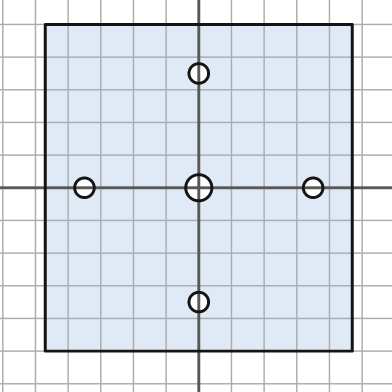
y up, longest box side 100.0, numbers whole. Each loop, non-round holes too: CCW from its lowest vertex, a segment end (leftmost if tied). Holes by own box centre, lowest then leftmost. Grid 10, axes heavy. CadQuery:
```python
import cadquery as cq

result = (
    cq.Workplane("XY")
    .moveTo(-47.0, -50.0)
    .lineTo(47.0, -50.0)
    .lineTo(47.0, 50.0)
    .lineTo(-47.0, 50.0)
    .close()
    .moveTo(0.0, -35.0)
    .circle(3.0)
    .moveTo(-35.0, 0.0)
    .circle(3.0)
    .moveTo(0.0, 0.0)
    .circle(4.0)
    .moveTo(35.0, 0.0)
    .circle(3.0)
    .moveTo(0.0, 35.0)
    .circle(3.0)
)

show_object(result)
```